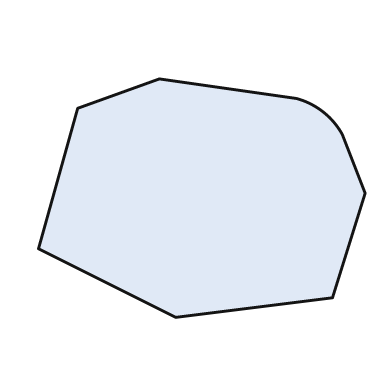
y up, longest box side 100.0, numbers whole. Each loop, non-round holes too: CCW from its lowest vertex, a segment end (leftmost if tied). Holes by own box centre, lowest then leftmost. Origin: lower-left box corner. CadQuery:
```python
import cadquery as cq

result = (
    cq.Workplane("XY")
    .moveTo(42.0, 0.0)
    .lineTo(90.0, 6.0)
    .lineTo(100.0, 38.0)
    .lineTo(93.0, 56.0)
    .threePointArc((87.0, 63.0), (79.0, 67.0))
    .lineTo(37.0, 73.0)
    .lineTo(12.0, 64.0)
    .lineTo(0.0, 21.0)
    .close()
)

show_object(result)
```